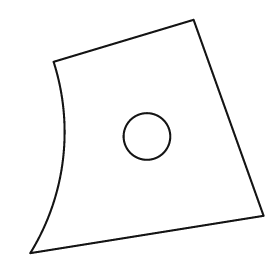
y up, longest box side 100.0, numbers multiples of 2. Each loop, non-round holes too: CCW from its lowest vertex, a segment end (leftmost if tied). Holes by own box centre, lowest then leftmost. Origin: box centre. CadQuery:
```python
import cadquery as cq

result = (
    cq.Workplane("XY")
    .moveTo(-50.0, -50.0)
    .lineTo(50.0, -34.0)
    .lineTo(20.0, 50.0)
    .lineTo(-40.0, 32.0)
    .threePointArc((-36.0, -10.0), (-50.0, -50.0))
    .close()
    .moveTo(0.0, 0.0)
    .circle(10.0)
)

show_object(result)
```